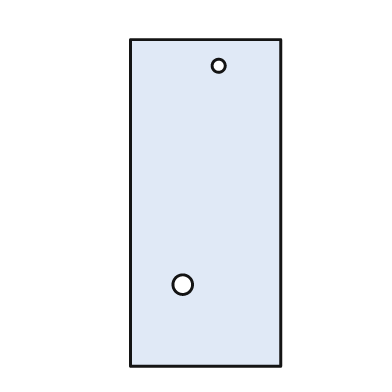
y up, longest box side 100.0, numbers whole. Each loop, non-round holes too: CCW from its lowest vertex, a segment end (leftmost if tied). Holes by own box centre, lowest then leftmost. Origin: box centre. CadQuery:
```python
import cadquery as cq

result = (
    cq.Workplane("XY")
    .moveTo(-23.0, -50.0)
    .lineTo(23.0, -50.0)
    .lineTo(23.0, 50.0)
    .lineTo(-23.0, 50.0)
    .close()
    .moveTo(-7.0, -25.0)
    .circle(3.0)
    .moveTo(4.0, 42.0)
    .circle(2.0)
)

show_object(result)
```